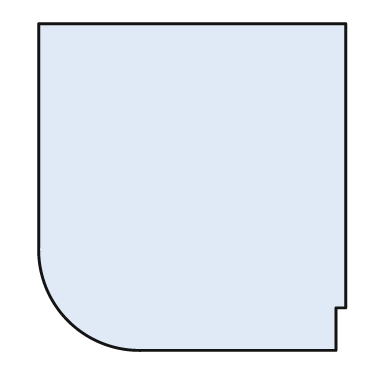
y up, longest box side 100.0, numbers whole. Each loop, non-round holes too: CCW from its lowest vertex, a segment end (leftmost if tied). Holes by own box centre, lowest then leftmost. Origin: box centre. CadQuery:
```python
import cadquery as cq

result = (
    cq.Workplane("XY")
    .moveTo(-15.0, -50.0)
    .lineTo(44.0, -50.0)
    .lineTo(44.0, -37.0)
    .lineTo(47.0, -37.0)
    .lineTo(47.0, 50.0)
    .lineTo(-47.0, 50.0)
    .lineTo(-47.0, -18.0)
    .threePointArc((-38.0, -41.0), (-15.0, -50.0))
    .close()
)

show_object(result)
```